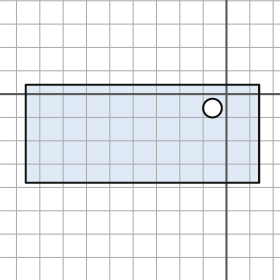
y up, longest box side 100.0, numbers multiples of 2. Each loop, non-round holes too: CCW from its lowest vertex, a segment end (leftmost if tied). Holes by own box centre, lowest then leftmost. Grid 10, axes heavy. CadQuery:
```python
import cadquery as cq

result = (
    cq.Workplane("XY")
    .moveTo(-86.0, -38.0)
    .lineTo(14.0, -38.0)
    .lineTo(14.0, 4.0)
    .lineTo(-86.0, 4.0)
    .close()
    .moveTo(-6.0, -6.0)
    .circle(4.0)
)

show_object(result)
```